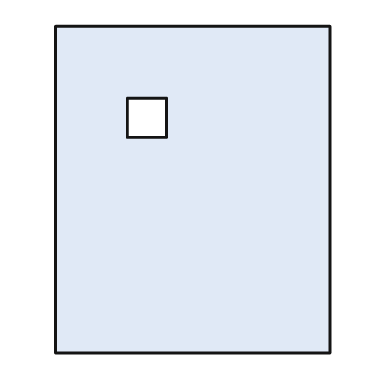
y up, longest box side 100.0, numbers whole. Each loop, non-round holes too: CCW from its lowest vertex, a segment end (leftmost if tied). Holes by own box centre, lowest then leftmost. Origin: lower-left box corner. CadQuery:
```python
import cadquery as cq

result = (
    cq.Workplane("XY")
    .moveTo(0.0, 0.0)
    .lineTo(84.0, 0.0)
    .lineTo(84.0, 100.0)
    .lineTo(0.0, 100.0)
    .close()
    .moveTo(22.0, 66.0)
    .lineTo(34.0, 66.0)
    .lineTo(34.0, 78.0)
    .lineTo(22.0, 78.0)
    .close()
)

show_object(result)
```